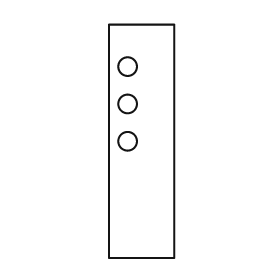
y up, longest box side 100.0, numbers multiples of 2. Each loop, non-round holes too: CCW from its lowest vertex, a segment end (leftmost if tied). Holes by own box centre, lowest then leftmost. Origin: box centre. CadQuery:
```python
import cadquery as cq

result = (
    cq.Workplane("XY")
    .moveTo(-14.0, -50.0)
    .lineTo(14.0, -50.0)
    .lineTo(14.0, 50.0)
    .lineTo(-14.0, 50.0)
    .close()
    .moveTo(-6.0, 0.0)
    .circle(4.0)
    .moveTo(-6.0, 16.0)
    .circle(4.0)
    .moveTo(-6.0, 32.0)
    .circle(4.0)
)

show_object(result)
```